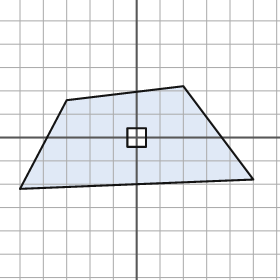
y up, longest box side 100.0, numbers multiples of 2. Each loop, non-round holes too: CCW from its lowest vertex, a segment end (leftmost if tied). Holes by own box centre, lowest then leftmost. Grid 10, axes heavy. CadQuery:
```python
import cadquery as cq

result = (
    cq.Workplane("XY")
    .moveTo(-50.0, -22.0)
    .lineTo(50.0, -18.0)
    .lineTo(20.0, 22.0)
    .lineTo(-30.0, 16.0)
    .close()
    .moveTo(-4.0, -4.0)
    .lineTo(4.0, -4.0)
    .lineTo(4.0, 4.0)
    .lineTo(-4.0, 4.0)
    .close()
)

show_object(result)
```